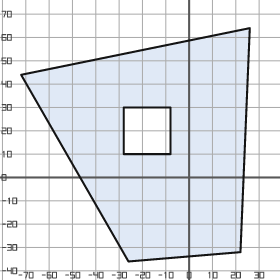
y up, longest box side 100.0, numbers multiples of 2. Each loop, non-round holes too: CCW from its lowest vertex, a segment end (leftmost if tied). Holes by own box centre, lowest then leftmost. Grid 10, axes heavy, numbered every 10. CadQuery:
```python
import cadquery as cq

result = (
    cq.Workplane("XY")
    .moveTo(-26.0, -36.0)
    .lineTo(22.0, -32.0)
    .lineTo(26.0, 64.0)
    .lineTo(-72.0, 44.0)
    .close()
    .moveTo(-28.0, 10.0)
    .lineTo(-8.0, 10.0)
    .lineTo(-8.0, 30.0)
    .lineTo(-28.0, 30.0)
    .close()
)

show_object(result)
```